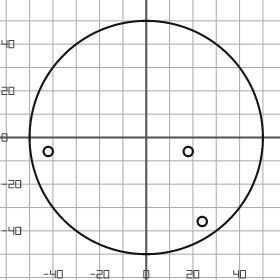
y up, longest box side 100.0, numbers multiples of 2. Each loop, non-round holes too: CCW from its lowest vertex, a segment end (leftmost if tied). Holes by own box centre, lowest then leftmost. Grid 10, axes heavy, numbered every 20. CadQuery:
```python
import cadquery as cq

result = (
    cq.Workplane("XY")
    .moveTo(0.0, 0.0)
    .circle(50.0)
    .moveTo(24.0, -36.0)
    .circle(2.0)
    .moveTo(-42.0, -6.0)
    .circle(2.0)
    .moveTo(18.0, -6.0)
    .circle(2.0)
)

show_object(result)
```